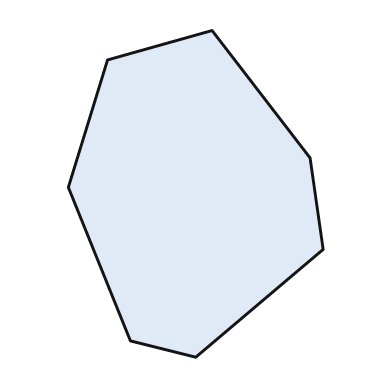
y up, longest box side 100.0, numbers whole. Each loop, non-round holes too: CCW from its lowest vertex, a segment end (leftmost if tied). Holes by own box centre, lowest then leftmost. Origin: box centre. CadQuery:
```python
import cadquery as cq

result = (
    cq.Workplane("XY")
    .moveTo(0.0, -50.0)
    .lineTo(39.0, -17.0)
    .lineTo(35.0, 11.0)
    .lineTo(5.0, 50.0)
    .lineTo(-27.0, 41.0)
    .lineTo(-39.0, 2.0)
    .lineTo(-20.0, -45.0)
    .close()
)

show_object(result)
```